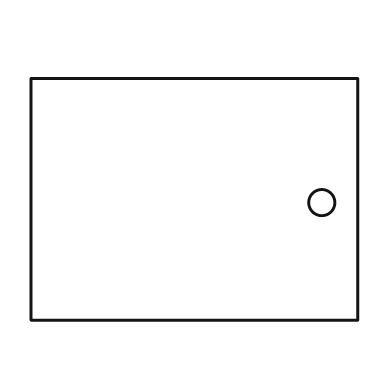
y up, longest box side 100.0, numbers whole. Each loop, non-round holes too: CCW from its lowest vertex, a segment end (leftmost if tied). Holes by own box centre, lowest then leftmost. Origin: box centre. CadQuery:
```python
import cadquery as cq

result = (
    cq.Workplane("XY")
    .moveTo(-50.0, -37.0)
    .lineTo(50.0, -37.0)
    .lineTo(50.0, 37.0)
    .lineTo(-50.0, 37.0)
    .close()
    .moveTo(39.0, -1.0)
    .circle(4.0)
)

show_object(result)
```